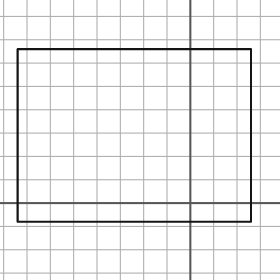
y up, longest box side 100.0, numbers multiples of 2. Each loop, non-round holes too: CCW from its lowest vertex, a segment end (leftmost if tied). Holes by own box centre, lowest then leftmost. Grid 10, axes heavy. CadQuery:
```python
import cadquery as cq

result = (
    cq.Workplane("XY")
    .moveTo(-74.0, -8.0)
    .lineTo(26.0, -8.0)
    .lineTo(26.0, 66.0)
    .lineTo(-74.0, 66.0)
    .close()
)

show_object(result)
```